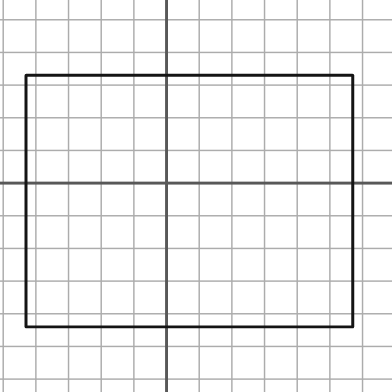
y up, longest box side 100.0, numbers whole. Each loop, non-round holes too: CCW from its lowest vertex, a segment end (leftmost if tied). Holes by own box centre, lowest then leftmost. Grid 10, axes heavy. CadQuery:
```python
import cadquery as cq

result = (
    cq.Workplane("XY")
    .moveTo(-43.0, -44.0)
    .lineTo(57.0, -44.0)
    .lineTo(57.0, 33.0)
    .lineTo(-43.0, 33.0)
    .close()
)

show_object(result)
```